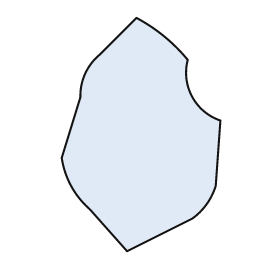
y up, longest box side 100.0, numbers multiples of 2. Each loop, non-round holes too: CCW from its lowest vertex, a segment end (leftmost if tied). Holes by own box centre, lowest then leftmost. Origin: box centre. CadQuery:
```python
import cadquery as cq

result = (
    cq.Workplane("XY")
    .moveTo(-6.0, -50.0)
    .lineTo(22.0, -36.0)
    .threePointArc((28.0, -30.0), (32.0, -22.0))
    .lineTo(34.0, 6.0)
    .threePointArc((22.0, 16.0), (20.0, 32.0))
    .threePointArc((10.0, 42.0), (-2.0, 50.0))
    .lineTo(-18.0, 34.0)
    .threePointArc((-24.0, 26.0), (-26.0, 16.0))
    .lineTo(-34.0, -10.0)
    .threePointArc((-30.0, -22.0), (-22.0, -32.0))
    .close()
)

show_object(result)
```